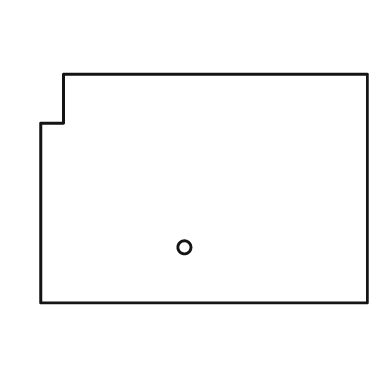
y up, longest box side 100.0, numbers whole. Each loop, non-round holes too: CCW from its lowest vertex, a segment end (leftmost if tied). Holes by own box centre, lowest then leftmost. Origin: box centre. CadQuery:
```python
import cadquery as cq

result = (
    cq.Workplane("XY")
    .moveTo(-50.0, -35.0)
    .lineTo(50.0, -35.0)
    .lineTo(50.0, 35.0)
    .lineTo(-43.0, 35.0)
    .lineTo(-43.0, 20.0)
    .lineTo(-50.0, 20.0)
    .close()
    .moveTo(-6.0, -18.0)
    .circle(2.0)
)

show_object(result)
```